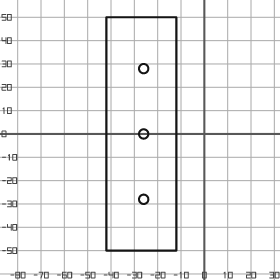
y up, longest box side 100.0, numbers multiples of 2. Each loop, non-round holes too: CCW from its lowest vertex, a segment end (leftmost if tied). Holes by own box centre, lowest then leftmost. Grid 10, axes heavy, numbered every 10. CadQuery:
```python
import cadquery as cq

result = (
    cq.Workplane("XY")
    .moveTo(-42.0, -50.0)
    .lineTo(-12.0, -50.0)
    .lineTo(-12.0, 50.0)
    .lineTo(-42.0, 50.0)
    .close()
    .moveTo(-26.0, -28.0)
    .circle(2.0)
    .moveTo(-26.0, 0.0)
    .circle(2.0)
    .moveTo(-26.0, 28.0)
    .circle(2.0)
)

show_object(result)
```